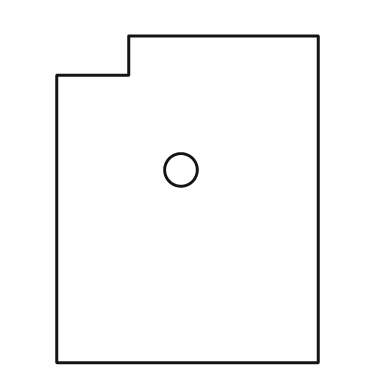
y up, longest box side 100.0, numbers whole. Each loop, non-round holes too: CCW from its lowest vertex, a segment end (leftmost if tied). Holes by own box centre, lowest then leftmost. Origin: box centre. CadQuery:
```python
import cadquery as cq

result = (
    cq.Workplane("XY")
    .moveTo(-40.0, -50.0)
    .lineTo(40.0, -50.0)
    .lineTo(40.0, 50.0)
    .lineTo(-18.0, 50.0)
    .lineTo(-18.0, 38.0)
    .lineTo(-40.0, 38.0)
    .close()
    .moveTo(-2.0, 9.0)
    .circle(5.0)
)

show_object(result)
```